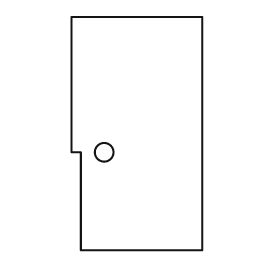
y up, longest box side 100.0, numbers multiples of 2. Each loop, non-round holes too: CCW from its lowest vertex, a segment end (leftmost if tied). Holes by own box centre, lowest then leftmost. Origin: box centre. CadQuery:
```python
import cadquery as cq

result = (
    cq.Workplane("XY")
    .moveTo(-24.0, -50.0)
    .lineTo(28.0, -50.0)
    .lineTo(28.0, 50.0)
    .lineTo(-28.0, 50.0)
    .lineTo(-28.0, -8.0)
    .lineTo(-24.0, -8.0)
    .close()
    .moveTo(-14.0, -8.0)
    .circle(4.0)
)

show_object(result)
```